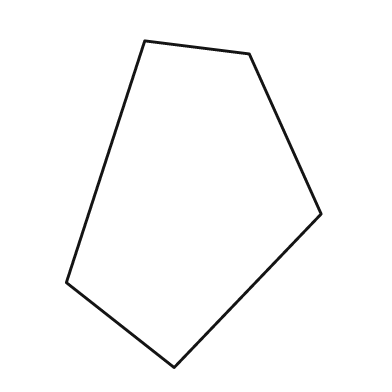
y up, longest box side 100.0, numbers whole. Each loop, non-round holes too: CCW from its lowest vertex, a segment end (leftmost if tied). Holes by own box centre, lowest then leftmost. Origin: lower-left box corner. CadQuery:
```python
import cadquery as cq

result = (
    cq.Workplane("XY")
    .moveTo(33.0, 0.0)
    .lineTo(78.0, 47.0)
    .lineTo(56.0, 96.0)
    .lineTo(24.0, 100.0)
    .lineTo(0.0, 26.0)
    .close()
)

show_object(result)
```